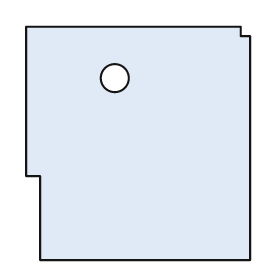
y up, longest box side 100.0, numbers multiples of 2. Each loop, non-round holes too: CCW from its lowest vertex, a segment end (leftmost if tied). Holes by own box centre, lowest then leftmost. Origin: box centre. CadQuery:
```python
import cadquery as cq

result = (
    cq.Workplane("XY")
    .moveTo(-42.0, -50.0)
    .lineTo(48.0, -50.0)
    .lineTo(48.0, 46.0)
    .lineTo(44.0, 46.0)
    .lineTo(44.0, 50.0)
    .lineTo(-48.0, 50.0)
    .lineTo(-48.0, -14.0)
    .lineTo(-42.0, -14.0)
    .close()
    .moveTo(-10.0, 28.0)
    .circle(6.0)
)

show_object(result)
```